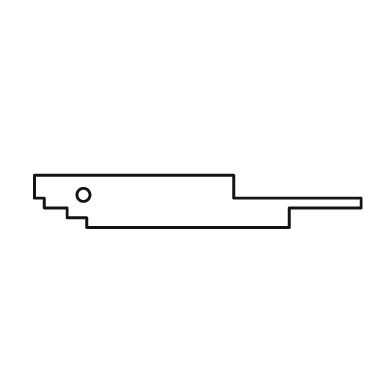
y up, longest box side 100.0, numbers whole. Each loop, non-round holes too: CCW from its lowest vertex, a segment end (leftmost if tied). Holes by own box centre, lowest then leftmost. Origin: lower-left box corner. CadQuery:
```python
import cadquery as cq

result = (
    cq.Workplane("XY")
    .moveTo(16.0, 0.0)
    .lineTo(78.0, 0.0)
    .lineTo(78.0, 6.0)
    .lineTo(100.0, 6.0)
    .lineTo(100.0, 9.0)
    .lineTo(61.0, 9.0)
    .lineTo(61.0, 16.0)
    .lineTo(0.0, 16.0)
    .lineTo(0.0, 9.0)
    .lineTo(3.0, 9.0)
    .lineTo(3.0, 6.0)
    .lineTo(10.0, 6.0)
    .lineTo(10.0, 3.0)
    .lineTo(16.0, 3.0)
    .close()
    .moveTo(15.0, 10.0)
    .circle(2.0)
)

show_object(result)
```